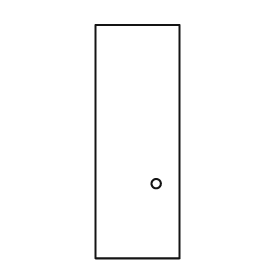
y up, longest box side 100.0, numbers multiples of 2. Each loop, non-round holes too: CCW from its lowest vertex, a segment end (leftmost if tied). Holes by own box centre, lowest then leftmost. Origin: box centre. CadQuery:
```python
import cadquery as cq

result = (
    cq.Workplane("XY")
    .moveTo(-18.0, -50.0)
    .lineTo(18.0, -50.0)
    .lineTo(18.0, 50.0)
    .lineTo(-18.0, 50.0)
    .close()
    .moveTo(8.0, -18.0)
    .circle(2.0)
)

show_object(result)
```